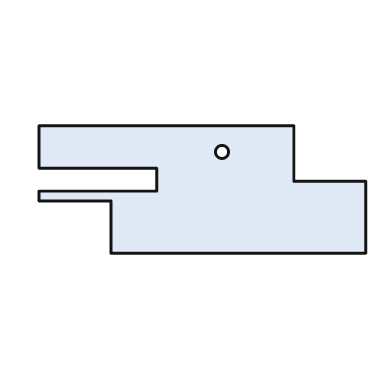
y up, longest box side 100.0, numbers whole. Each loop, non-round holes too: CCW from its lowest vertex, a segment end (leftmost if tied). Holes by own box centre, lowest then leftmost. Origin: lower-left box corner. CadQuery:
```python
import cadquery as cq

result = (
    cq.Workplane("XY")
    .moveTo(22.0, 0.0)
    .lineTo(100.0, 0.0)
    .lineTo(100.0, 22.0)
    .lineTo(78.0, 22.0)
    .lineTo(78.0, 39.0)
    .lineTo(0.0, 39.0)
    .lineTo(0.0, 26.0)
    .lineTo(36.0, 26.0)
    .lineTo(36.0, 19.0)
    .lineTo(0.0, 19.0)
    .lineTo(0.0, 16.0)
    .lineTo(22.0, 16.0)
    .close()
    .moveTo(56.0, 31.0)
    .circle(2.0)
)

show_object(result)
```